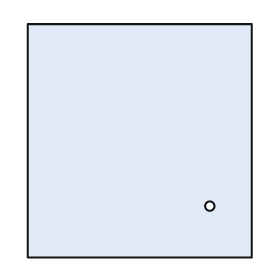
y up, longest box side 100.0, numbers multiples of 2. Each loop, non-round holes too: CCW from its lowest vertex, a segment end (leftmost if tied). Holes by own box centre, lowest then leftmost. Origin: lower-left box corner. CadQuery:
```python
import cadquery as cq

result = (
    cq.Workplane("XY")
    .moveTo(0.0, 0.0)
    .lineTo(96.0, 0.0)
    .lineTo(96.0, 100.0)
    .lineTo(0.0, 100.0)
    .close()
    .moveTo(78.0, 22.0)
    .circle(2.0)
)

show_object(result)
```